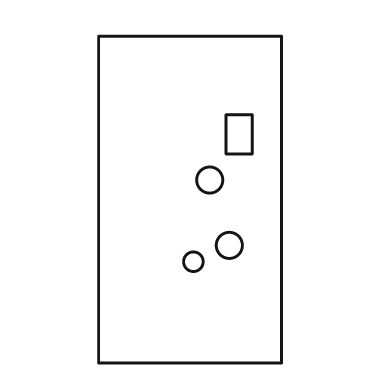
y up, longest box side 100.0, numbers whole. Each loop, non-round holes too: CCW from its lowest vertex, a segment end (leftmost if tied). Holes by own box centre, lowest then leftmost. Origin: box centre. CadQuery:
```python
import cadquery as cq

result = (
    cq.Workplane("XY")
    .moveTo(-28.0, -50.0)
    .lineTo(28.0, -50.0)
    .lineTo(28.0, 50.0)
    .lineTo(-28.0, 50.0)
    .close()
    .moveTo(1.0, -19.0)
    .circle(3.0)
    .moveTo(12.0, -14.0)
    .circle(4.0)
    .moveTo(6.0, 6.0)
    .circle(4.0)
    .moveTo(11.0, 14.0)
    .lineTo(19.0, 14.0)
    .lineTo(19.0, 26.0)
    .lineTo(11.0, 26.0)
    .close()
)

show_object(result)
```